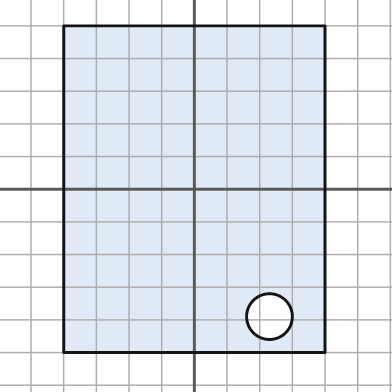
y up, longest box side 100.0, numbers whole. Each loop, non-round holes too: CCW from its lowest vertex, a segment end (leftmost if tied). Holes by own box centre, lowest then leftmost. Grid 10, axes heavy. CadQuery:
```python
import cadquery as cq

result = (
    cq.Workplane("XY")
    .moveTo(-40.0, -50.0)
    .lineTo(40.0, -50.0)
    .lineTo(40.0, 50.0)
    .lineTo(-40.0, 50.0)
    .close()
    .moveTo(23.0, -39.0)
    .circle(7.0)
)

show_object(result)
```